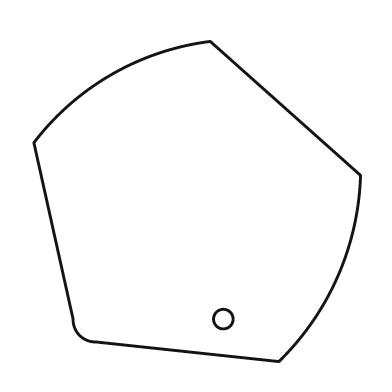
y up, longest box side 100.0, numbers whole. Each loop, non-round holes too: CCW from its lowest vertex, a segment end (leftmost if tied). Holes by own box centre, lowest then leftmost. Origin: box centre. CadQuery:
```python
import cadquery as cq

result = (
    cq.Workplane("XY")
    .moveTo(25.0, -49.0)
    .threePointArc((43.0, -23.0), (50.0, 8.0))
    .lineTo(4.0, 49.0)
    .threePointArc((-26.0, 39.0), (-50.0, 18.0))
    .lineTo(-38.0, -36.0)
    .threePointArc((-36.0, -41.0), (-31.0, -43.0))
    .close()
    .moveTo(8.0, -36.0)
    .circle(3.0)
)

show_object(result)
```